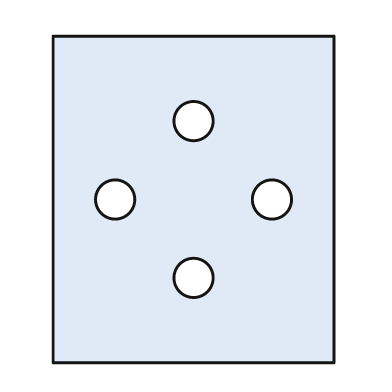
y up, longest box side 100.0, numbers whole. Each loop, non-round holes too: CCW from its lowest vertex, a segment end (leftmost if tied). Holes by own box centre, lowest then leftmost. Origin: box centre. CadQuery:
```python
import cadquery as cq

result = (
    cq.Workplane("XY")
    .moveTo(-43.0, -50.0)
    .lineTo(43.0, -50.0)
    .lineTo(43.0, 50.0)
    .lineTo(-43.0, 50.0)
    .close()
    .moveTo(0.0, -24.0)
    .circle(6.0)
    .moveTo(-24.0, 0.0)
    .circle(6.0)
    .moveTo(24.0, 0.0)
    .circle(6.0)
    .moveTo(0.0, 24.0)
    .circle(6.0)
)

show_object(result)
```